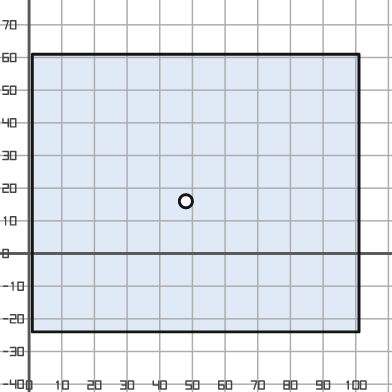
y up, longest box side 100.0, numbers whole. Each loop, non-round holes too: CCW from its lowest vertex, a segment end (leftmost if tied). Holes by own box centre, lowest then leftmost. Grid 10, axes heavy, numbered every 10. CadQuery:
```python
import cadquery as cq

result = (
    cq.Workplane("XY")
    .moveTo(1.0, -24.0)
    .lineTo(101.0, -24.0)
    .lineTo(101.0, 61.0)
    .lineTo(1.0, 61.0)
    .close()
    .moveTo(48.0, 16.0)
    .circle(2.0)
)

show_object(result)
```